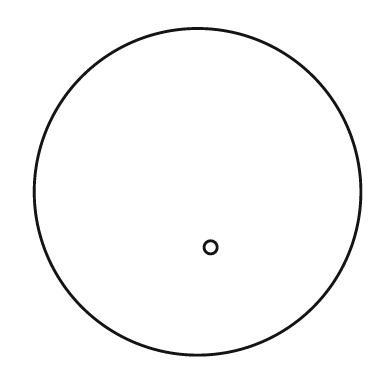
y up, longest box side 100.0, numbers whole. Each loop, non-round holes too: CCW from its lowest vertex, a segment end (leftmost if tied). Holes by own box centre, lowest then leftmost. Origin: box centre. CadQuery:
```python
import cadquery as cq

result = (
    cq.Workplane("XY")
    .moveTo(0.0, 0.0)
    .circle(50.0)
    .moveTo(4.0, -17.0)
    .circle(2.0)
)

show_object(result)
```